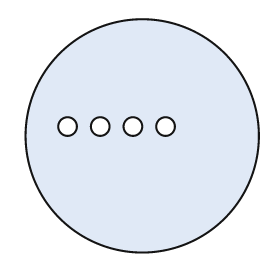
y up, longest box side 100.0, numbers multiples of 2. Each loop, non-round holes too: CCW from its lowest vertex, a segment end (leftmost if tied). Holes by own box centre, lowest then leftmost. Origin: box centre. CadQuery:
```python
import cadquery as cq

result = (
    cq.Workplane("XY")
    .moveTo(0.0, 0.0)
    .circle(50.0)
    .moveTo(-32.0, 4.0)
    .circle(4.0)
    .moveTo(-18.0, 4.0)
    .circle(4.0)
    .moveTo(-4.0, 4.0)
    .circle(4.0)
    .moveTo(10.0, 4.0)
    .circle(4.0)
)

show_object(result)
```